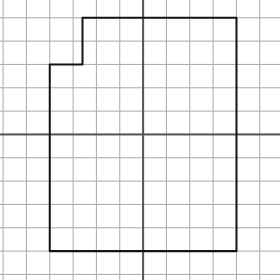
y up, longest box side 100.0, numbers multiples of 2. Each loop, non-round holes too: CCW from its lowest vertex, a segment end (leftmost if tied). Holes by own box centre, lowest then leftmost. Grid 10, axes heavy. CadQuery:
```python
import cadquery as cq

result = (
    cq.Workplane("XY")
    .moveTo(-40.0, -50.0)
    .lineTo(40.0, -50.0)
    .lineTo(40.0, 50.0)
    .lineTo(-26.0, 50.0)
    .lineTo(-26.0, 30.0)
    .lineTo(-40.0, 30.0)
    .close()
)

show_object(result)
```